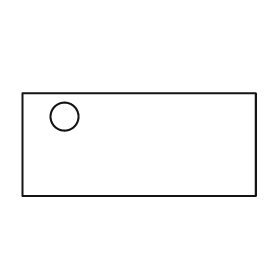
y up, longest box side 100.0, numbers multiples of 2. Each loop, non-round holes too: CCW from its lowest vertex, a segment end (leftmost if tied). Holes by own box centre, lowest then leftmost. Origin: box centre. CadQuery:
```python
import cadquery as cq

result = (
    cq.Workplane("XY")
    .moveTo(-50.0, -22.0)
    .lineTo(50.0, -22.0)
    .lineTo(50.0, 22.0)
    .lineTo(-50.0, 22.0)
    .close()
    .moveTo(-32.0, 12.0)
    .circle(6.0)
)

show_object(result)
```